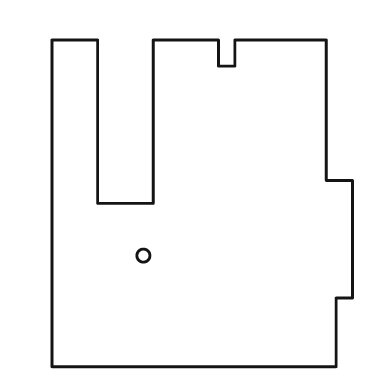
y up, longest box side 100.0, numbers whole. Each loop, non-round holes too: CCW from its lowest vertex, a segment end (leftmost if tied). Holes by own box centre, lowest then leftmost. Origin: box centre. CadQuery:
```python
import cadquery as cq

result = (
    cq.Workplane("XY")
    .moveTo(-46.0, -50.0)
    .lineTo(41.0, -50.0)
    .lineTo(41.0, -29.0)
    .lineTo(46.0, -29.0)
    .lineTo(46.0, 7.0)
    .lineTo(38.0, 7.0)
    .lineTo(38.0, 50.0)
    .lineTo(10.0, 50.0)
    .lineTo(10.0, 42.0)
    .lineTo(5.0, 42.0)
    .lineTo(5.0, 50.0)
    .lineTo(-15.0, 50.0)
    .lineTo(-15.0, 0.0)
    .lineTo(-32.0, 0.0)
    .lineTo(-32.0, 50.0)
    .lineTo(-46.0, 50.0)
    .close()
    .moveTo(-18.0, -16.0)
    .circle(2.0)
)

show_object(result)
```